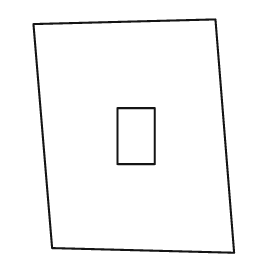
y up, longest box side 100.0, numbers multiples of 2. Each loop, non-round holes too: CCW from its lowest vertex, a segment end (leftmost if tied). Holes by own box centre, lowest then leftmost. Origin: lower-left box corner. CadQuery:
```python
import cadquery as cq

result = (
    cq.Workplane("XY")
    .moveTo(86.0, 0.0)
    .lineTo(78.0, 100.0)
    .lineTo(0.0, 98.0)
    .lineTo(8.0, 2.0)
    .close()
    .moveTo(36.0, 38.0)
    .lineTo(52.0, 38.0)
    .lineTo(52.0, 62.0)
    .lineTo(36.0, 62.0)
    .close()
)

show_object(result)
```